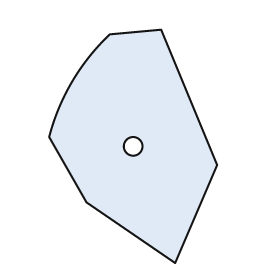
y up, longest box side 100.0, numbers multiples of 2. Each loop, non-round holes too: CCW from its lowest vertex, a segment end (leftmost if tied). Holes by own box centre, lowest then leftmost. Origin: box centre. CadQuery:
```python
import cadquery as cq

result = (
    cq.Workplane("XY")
    .moveTo(18.0, -50.0)
    .lineTo(36.0, -8.0)
    .lineTo(12.0, 50.0)
    .lineTo(-10.0, 48.0)
    .threePointArc((-26.0, 28.0), (-36.0, 4.0))
    .lineTo(-20.0, -24.0)
    .close()
    .moveTo(0.0, 0.0)
    .circle(4.0)
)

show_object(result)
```